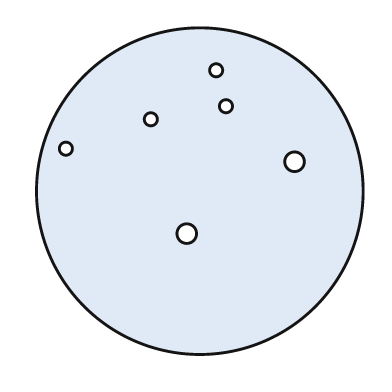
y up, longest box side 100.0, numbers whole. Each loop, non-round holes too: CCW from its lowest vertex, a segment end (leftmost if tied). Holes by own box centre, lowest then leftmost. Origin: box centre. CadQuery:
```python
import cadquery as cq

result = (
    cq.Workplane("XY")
    .moveTo(0.0, 0.0)
    .circle(50.0)
    .moveTo(-4.0, -13.0)
    .circle(3.0)
    .moveTo(29.0, 9.0)
    .circle(3.0)
    .moveTo(-41.0, 13.0)
    .circle(2.0)
    .moveTo(-15.0, 22.0)
    .circle(2.0)
    .moveTo(8.0, 26.0)
    .circle(2.0)
    .moveTo(5.0, 37.0)
    .circle(2.0)
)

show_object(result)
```